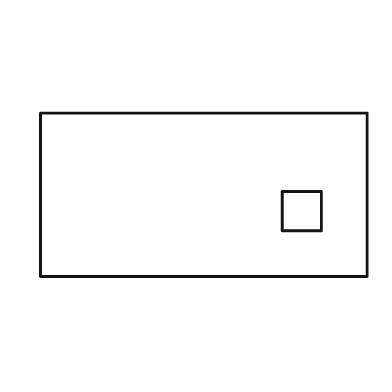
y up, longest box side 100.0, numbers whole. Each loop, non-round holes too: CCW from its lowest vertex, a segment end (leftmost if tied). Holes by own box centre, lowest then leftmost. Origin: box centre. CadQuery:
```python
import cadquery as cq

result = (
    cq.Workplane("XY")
    .moveTo(-50.0, -25.0)
    .lineTo(50.0, -25.0)
    .lineTo(50.0, 25.0)
    .lineTo(-50.0, 25.0)
    .close()
    .moveTo(24.0, -11.0)
    .lineTo(36.0, -11.0)
    .lineTo(36.0, 1.0)
    .lineTo(24.0, 1.0)
    .close()
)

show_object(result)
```